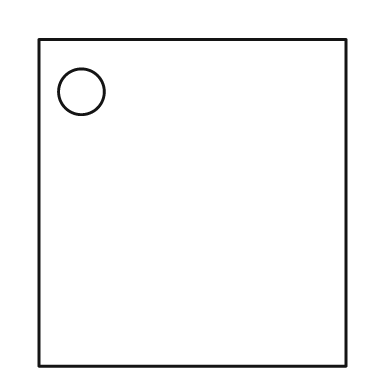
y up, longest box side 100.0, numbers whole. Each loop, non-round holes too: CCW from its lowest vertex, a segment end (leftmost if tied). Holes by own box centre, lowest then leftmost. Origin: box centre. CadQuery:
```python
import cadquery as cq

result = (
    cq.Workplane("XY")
    .moveTo(-47.0, -50.0)
    .lineTo(47.0, -50.0)
    .lineTo(47.0, 50.0)
    .lineTo(-47.0, 50.0)
    .close()
    .moveTo(-34.0, 34.0)
    .circle(7.0)
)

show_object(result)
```